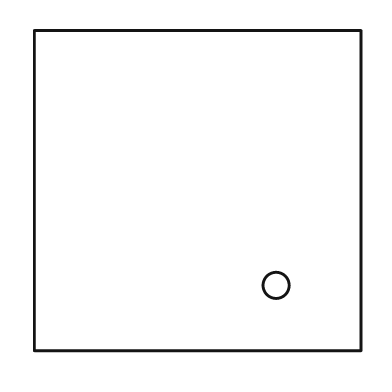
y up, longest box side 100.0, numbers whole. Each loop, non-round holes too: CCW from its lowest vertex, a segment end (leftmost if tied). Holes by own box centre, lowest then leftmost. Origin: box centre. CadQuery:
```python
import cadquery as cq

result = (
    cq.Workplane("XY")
    .moveTo(-50.0, -49.0)
    .lineTo(50.0, -49.0)
    .lineTo(50.0, 49.0)
    .lineTo(-50.0, 49.0)
    .close()
    .moveTo(24.0, -29.0)
    .circle(4.0)
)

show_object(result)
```